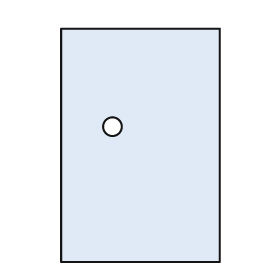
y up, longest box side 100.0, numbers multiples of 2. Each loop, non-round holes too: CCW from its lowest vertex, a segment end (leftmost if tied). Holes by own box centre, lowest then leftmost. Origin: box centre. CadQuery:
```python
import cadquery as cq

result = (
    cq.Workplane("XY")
    .moveTo(-34.0, -50.0)
    .lineTo(34.0, -50.0)
    .lineTo(34.0, 50.0)
    .lineTo(-34.0, 50.0)
    .close()
    .moveTo(-12.0, 8.0)
    .circle(4.0)
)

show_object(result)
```